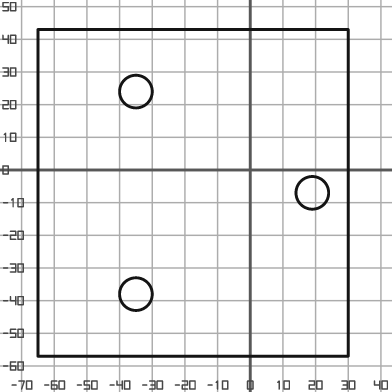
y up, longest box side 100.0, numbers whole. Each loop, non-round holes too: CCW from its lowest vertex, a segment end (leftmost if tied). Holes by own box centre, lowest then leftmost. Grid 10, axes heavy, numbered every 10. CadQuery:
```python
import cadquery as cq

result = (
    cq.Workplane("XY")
    .moveTo(-65.0, -57.0)
    .lineTo(30.0, -57.0)
    .lineTo(30.0, 43.0)
    .lineTo(-65.0, 43.0)
    .close()
    .moveTo(-35.0, -38.0)
    .circle(5.0)
    .moveTo(19.0, -7.0)
    .circle(5.0)
    .moveTo(-35.0, 24.0)
    .circle(5.0)
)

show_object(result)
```